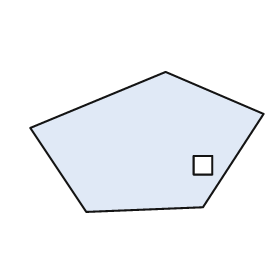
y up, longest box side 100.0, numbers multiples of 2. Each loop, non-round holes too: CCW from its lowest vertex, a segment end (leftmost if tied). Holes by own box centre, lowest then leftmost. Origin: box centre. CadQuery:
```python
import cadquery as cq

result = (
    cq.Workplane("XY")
    .moveTo(-26.0, -30.0)
    .lineTo(24.0, -28.0)
    .lineTo(50.0, 12.0)
    .lineTo(8.0, 30.0)
    .lineTo(-50.0, 6.0)
    .close()
    .moveTo(20.0, -14.0)
    .lineTo(28.0, -14.0)
    .lineTo(28.0, -6.0)
    .lineTo(20.0, -6.0)
    .close()
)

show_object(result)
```